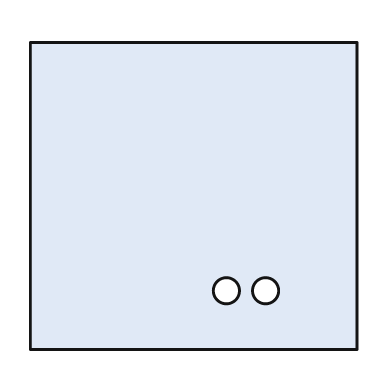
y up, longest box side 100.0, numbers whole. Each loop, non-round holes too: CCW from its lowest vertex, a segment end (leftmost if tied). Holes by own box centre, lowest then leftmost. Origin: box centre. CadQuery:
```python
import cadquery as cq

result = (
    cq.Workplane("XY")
    .moveTo(-50.0, -47.0)
    .lineTo(50.0, -47.0)
    .lineTo(50.0, 47.0)
    .lineTo(-50.0, 47.0)
    .close()
    .moveTo(10.0, -29.0)
    .circle(4.0)
    .moveTo(22.0, -29.0)
    .circle(4.0)
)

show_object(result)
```